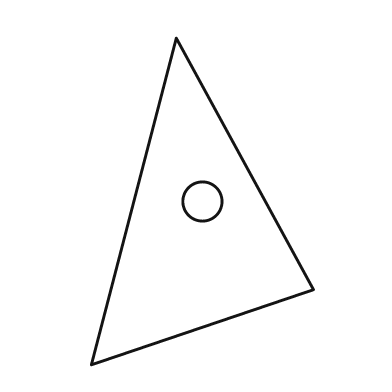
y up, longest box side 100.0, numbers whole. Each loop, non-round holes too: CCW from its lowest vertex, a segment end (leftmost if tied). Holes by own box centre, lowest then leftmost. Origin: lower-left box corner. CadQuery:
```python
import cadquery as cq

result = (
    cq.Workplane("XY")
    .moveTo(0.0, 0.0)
    .lineTo(68.0, 23.0)
    .lineTo(26.0, 100.0)
    .close()
    .moveTo(34.0, 50.0)
    .circle(6.0)
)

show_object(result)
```